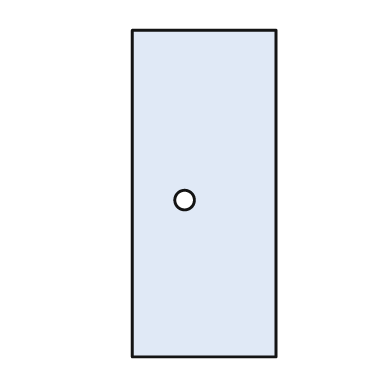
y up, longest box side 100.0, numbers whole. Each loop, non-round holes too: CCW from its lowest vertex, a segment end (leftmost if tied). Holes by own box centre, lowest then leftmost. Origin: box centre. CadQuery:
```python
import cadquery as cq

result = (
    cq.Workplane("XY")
    .moveTo(-22.0, -50.0)
    .lineTo(22.0, -50.0)
    .lineTo(22.0, 50.0)
    .lineTo(-22.0, 50.0)
    .close()
    .moveTo(-6.0, -2.0)
    .circle(3.0)
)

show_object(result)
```